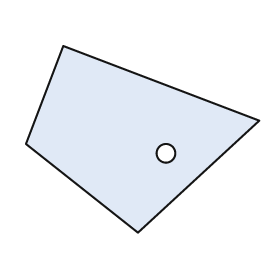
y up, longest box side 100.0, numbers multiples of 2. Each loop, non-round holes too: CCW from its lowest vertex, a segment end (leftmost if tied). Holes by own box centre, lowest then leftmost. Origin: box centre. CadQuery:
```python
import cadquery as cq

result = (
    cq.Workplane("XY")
    .moveTo(-2.0, -40.0)
    .lineTo(50.0, 8.0)
    .lineTo(-34.0, 40.0)
    .lineTo(-50.0, -2.0)
    .close()
    .moveTo(10.0, -6.0)
    .circle(4.0)
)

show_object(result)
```